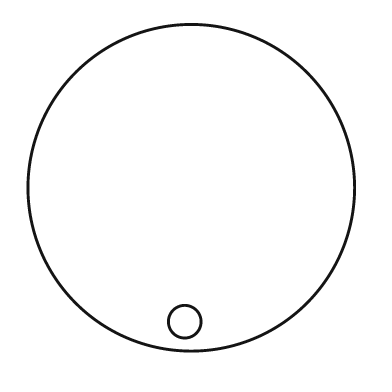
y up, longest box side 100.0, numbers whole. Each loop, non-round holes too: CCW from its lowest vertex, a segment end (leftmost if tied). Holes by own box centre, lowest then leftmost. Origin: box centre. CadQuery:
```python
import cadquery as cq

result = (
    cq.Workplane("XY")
    .moveTo(0.0, 0.0)
    .circle(50.0)
    .moveTo(-2.0, -41.0)
    .circle(5.0)
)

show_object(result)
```